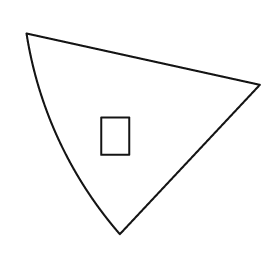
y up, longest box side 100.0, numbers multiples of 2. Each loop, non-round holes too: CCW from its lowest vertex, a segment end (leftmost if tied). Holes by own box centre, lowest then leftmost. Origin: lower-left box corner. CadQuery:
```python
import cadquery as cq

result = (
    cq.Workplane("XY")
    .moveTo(40.0, 0.0)
    .lineTo(100.0, 64.0)
    .lineTo(0.0, 86.0)
    .threePointArc((14.0, 40.0), (40.0, 0.0))
    .close()
    .moveTo(32.0, 34.0)
    .lineTo(44.0, 34.0)
    .lineTo(44.0, 50.0)
    .lineTo(32.0, 50.0)
    .close()
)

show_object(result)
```